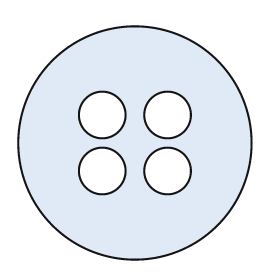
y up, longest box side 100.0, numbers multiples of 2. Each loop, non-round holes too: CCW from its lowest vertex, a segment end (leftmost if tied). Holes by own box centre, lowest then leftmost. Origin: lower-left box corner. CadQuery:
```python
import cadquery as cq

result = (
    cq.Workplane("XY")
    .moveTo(50.0, 50.0)
    .circle(50.0)
    .moveTo(36.0, 38.0)
    .circle(10.0)
    .moveTo(64.0, 38.0)
    .circle(10.0)
    .moveTo(36.0, 62.0)
    .circle(10.0)
    .moveTo(64.0, 62.0)
    .circle(10.0)
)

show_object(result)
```